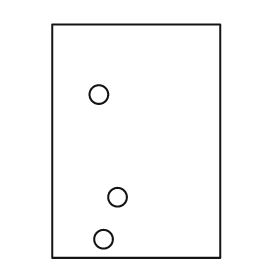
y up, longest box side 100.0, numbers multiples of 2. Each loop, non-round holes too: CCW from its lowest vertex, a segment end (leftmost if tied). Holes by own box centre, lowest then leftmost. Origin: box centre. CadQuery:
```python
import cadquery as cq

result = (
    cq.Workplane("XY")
    .moveTo(-36.0, -50.0)
    .lineTo(36.0, -50.0)
    .lineTo(36.0, 50.0)
    .lineTo(-36.0, 50.0)
    .close()
    .moveTo(-14.0, -42.0)
    .circle(4.0)
    .moveTo(-8.0, -24.0)
    .circle(4.0)
    .moveTo(-16.0, 20.0)
    .circle(4.0)
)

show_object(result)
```